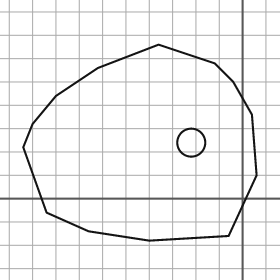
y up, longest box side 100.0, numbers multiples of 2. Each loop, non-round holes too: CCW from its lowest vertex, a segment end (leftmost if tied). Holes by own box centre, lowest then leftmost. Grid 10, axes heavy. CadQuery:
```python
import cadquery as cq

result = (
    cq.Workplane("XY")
    .moveTo(-40.0, -18.0)
    .lineTo(-6.0, -16.0)
    .lineTo(6.0, 10.0)
    .lineTo(4.0, 36.0)
    .lineTo(-4.0, 50.0)
    .lineTo(-12.0, 58.0)
    .lineTo(-36.0, 66.0)
    .lineTo(-62.0, 56.0)
    .lineTo(-80.0, 44.0)
    .lineTo(-90.0, 32.0)
    .lineTo(-94.0, 22.0)
    .lineTo(-84.0, -6.0)
    .lineTo(-66.0, -14.0)
    .close()
    .moveTo(-22.0, 24.0)
    .circle(6.0)
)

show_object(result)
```